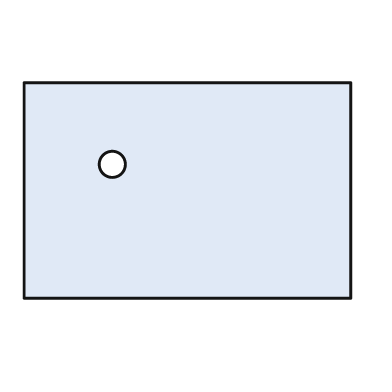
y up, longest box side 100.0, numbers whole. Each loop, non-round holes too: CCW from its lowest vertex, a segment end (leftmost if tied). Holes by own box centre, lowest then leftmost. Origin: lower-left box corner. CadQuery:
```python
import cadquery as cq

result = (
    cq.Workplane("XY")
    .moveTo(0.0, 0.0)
    .lineTo(100.0, 0.0)
    .lineTo(100.0, 66.0)
    .lineTo(0.0, 66.0)
    .close()
    .moveTo(27.0, 41.0)
    .circle(4.0)
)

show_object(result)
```